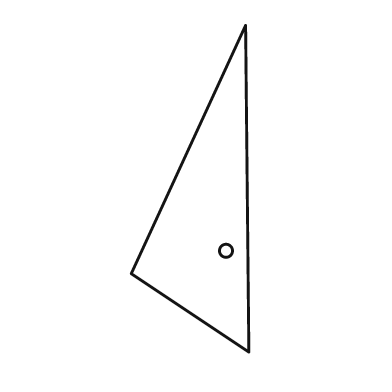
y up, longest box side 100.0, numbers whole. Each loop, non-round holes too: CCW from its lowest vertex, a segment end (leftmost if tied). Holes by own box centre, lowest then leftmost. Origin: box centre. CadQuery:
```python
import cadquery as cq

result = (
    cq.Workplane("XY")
    .moveTo(18.0, -50.0)
    .lineTo(17.0, 50.0)
    .lineTo(-18.0, -26.0)
    .close()
    .moveTo(11.0, -19.0)
    .circle(2.0)
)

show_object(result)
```